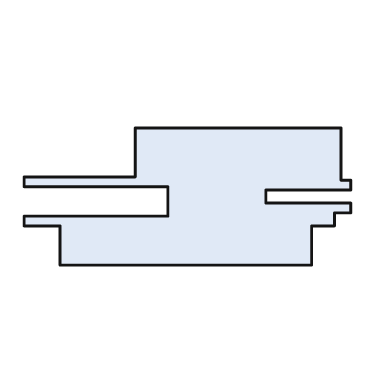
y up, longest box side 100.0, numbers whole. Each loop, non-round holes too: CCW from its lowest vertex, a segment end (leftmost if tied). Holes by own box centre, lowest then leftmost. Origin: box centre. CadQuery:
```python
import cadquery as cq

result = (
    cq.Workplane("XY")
    .moveTo(-39.0, -21.0)
    .lineTo(38.0, -21.0)
    .lineTo(38.0, -9.0)
    .lineTo(45.0, -9.0)
    .lineTo(45.0, -5.0)
    .lineTo(50.0, -5.0)
    .lineTo(50.0, -2.0)
    .lineTo(24.0, -2.0)
    .lineTo(24.0, 2.0)
    .lineTo(50.0, 2.0)
    .lineTo(50.0, 5.0)
    .lineTo(47.0, 5.0)
    .lineTo(47.0, 21.0)
    .lineTo(-16.0, 21.0)
    .lineTo(-16.0, 6.0)
    .lineTo(-50.0, 6.0)
    .lineTo(-50.0, 3.0)
    .lineTo(-6.0, 3.0)
    .lineTo(-6.0, -6.0)
    .lineTo(-50.0, -6.0)
    .lineTo(-50.0, -9.0)
    .lineTo(-39.0, -9.0)
    .close()
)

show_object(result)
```